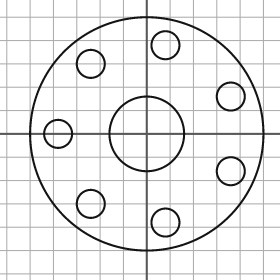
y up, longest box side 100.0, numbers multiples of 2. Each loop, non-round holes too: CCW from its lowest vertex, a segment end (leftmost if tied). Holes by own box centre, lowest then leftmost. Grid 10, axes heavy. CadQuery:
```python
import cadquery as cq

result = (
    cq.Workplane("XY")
    .moveTo(0.0, 0.0)
    .circle(50.0)
    .moveTo(8.0, -38.0)
    .circle(6.0)
    .moveTo(-24.0, -30.0)
    .circle(6.0)
    .moveTo(36.0, -16.0)
    .circle(6.0)
    .moveTo(-38.0, 0.0)
    .circle(6.0)
    .moveTo(0.0, 0.0)
    .circle(16.0)
    .moveTo(36.0, 16.0)
    .circle(6.0)
    .moveTo(-24.0, 30.0)
    .circle(6.0)
    .moveTo(8.0, 38.0)
    .circle(6.0)
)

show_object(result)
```